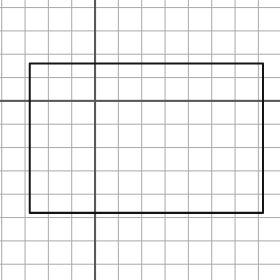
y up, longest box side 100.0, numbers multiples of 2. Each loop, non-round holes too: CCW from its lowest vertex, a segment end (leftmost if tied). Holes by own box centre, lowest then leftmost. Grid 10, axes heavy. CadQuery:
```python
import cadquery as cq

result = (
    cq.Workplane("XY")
    .moveTo(-28.0, -48.0)
    .lineTo(72.0, -48.0)
    .lineTo(72.0, 16.0)
    .lineTo(-28.0, 16.0)
    .close()
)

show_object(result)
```